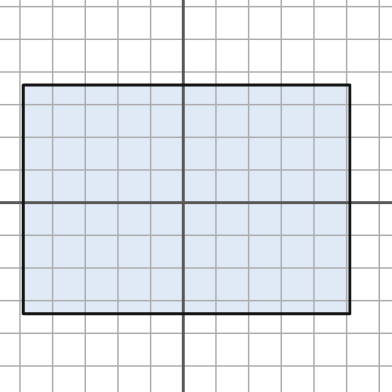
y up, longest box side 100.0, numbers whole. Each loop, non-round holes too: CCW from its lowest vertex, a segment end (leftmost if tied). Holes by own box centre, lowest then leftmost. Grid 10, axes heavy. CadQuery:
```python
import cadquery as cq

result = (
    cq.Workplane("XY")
    .moveTo(-49.0, -34.0)
    .lineTo(51.0, -34.0)
    .lineTo(51.0, 36.0)
    .lineTo(-49.0, 36.0)
    .close()
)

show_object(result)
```